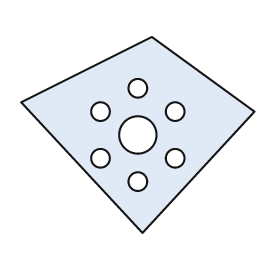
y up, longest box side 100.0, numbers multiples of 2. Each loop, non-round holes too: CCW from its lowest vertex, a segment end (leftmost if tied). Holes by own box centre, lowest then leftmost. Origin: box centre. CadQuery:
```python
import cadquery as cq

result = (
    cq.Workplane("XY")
    .moveTo(2.0, -42.0)
    .lineTo(50.0, 10.0)
    .lineTo(6.0, 42.0)
    .lineTo(-50.0, 14.0)
    .close()
    .moveTo(0.0, -20.0)
    .circle(4.0)
    .moveTo(-16.0, -10.0)
    .circle(4.0)
    .moveTo(16.0, -10.0)
    .circle(4.0)
    .moveTo(0.0, 0.0)
    .circle(8.0)
    .moveTo(-16.0, 10.0)
    .circle(4.0)
    .moveTo(16.0, 10.0)
    .circle(4.0)
    .moveTo(0.0, 20.0)
    .circle(4.0)
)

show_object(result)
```